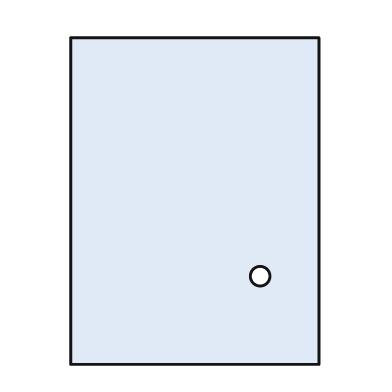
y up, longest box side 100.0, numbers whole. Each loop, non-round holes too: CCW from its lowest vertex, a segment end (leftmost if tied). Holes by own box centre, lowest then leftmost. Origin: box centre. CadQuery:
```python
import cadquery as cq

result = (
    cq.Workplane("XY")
    .moveTo(-38.0, -50.0)
    .lineTo(38.0, -50.0)
    .lineTo(38.0, 50.0)
    .lineTo(-38.0, 50.0)
    .close()
    .moveTo(20.0, -23.0)
    .circle(3.0)
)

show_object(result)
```